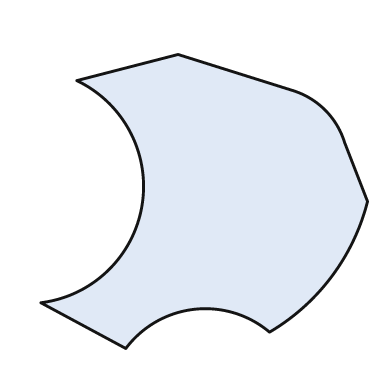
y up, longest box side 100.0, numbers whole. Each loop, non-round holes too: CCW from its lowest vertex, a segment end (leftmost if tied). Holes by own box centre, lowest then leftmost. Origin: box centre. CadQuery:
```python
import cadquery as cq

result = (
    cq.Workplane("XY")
    .moveTo(-24.0, -45.0)
    .threePointArc((-3.0, -33.0), (20.0, -40.0))
    .threePointArc((39.0, -23.0), (50.0, 0.0))
    .lineTo(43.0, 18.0)
    .threePointArc((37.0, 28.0), (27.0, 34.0))
    .lineTo(-8.0, 45.0)
    .lineTo(-39.0, 37.0)
    .threePointArc((-19.0, -1.0), (-50.0, -31.0))
    .close()
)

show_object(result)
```